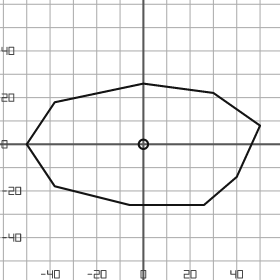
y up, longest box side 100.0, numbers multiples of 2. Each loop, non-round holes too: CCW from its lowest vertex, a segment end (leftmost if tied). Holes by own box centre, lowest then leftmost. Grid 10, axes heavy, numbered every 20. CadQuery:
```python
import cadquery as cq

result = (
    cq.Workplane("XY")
    .moveTo(-6.0, -26.0)
    .lineTo(26.0, -26.0)
    .lineTo(40.0, -14.0)
    .lineTo(50.0, 8.0)
    .lineTo(30.0, 22.0)
    .lineTo(0.0, 26.0)
    .lineTo(-38.0, 18.0)
    .lineTo(-50.0, 0.0)
    .lineTo(-38.0, -18.0)
    .close()
    .moveTo(0.0, 0.0)
    .circle(2.0)
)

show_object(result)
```